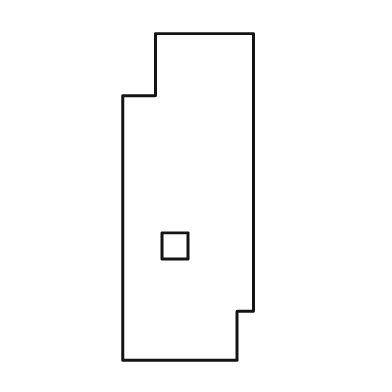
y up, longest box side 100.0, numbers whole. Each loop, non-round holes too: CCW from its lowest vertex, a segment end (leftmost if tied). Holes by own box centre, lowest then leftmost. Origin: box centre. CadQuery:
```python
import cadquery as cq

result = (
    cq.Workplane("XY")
    .moveTo(-20.0, -50.0)
    .lineTo(15.0, -50.0)
    .lineTo(15.0, -35.0)
    .lineTo(20.0, -35.0)
    .lineTo(20.0, 50.0)
    .lineTo(-10.0, 50.0)
    .lineTo(-10.0, 31.0)
    .lineTo(-20.0, 31.0)
    .close()
    .moveTo(-8.0, -19.0)
    .lineTo(0.0, -19.0)
    .lineTo(0.0, -11.0)
    .lineTo(-8.0, -11.0)
    .close()
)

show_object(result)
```